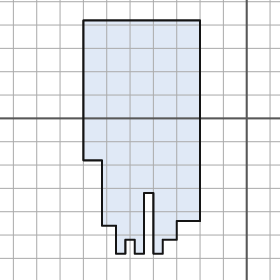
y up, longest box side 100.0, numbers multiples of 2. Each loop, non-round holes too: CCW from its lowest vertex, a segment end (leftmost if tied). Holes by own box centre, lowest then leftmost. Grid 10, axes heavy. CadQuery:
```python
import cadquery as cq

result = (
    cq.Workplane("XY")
    .moveTo(-56.0, -58.0)
    .lineTo(-52.0, -58.0)
    .lineTo(-52.0, -52.0)
    .lineTo(-48.0, -52.0)
    .lineTo(-48.0, -58.0)
    .lineTo(-44.0, -58.0)
    .lineTo(-44.0, -32.0)
    .lineTo(-40.0, -32.0)
    .lineTo(-40.0, -58.0)
    .lineTo(-36.0, -58.0)
    .lineTo(-36.0, -52.0)
    .lineTo(-30.0, -52.0)
    .lineTo(-30.0, -44.0)
    .lineTo(-20.0, -44.0)
    .lineTo(-20.0, 42.0)
    .lineTo(-70.0, 42.0)
    .lineTo(-70.0, -18.0)
    .lineTo(-62.0, -18.0)
    .lineTo(-62.0, -46.0)
    .lineTo(-56.0, -46.0)
    .close()
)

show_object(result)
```